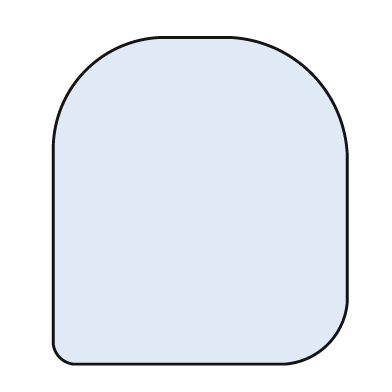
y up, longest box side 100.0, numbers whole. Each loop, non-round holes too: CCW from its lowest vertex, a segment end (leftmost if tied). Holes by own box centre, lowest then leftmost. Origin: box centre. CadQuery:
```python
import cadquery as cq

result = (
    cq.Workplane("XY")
    .moveTo(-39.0, -50.0)
    .lineTo(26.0, -50.0)
    .threePointArc((39.0, -44.0), (45.0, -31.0))
    .lineTo(45.0, 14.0)
    .threePointArc((34.0, 39.0), (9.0, 50.0))
    .lineTo(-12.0, 50.0)
    .threePointArc((-35.0, 40.0), (-45.0, 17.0))
    .lineTo(-45.0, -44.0)
    .threePointArc((-43.0, -48.0), (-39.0, -50.0))
    .close()
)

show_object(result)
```